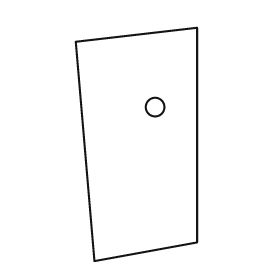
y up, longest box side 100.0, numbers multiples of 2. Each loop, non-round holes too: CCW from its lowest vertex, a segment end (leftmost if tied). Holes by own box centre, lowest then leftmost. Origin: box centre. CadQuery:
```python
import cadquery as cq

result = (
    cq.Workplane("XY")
    .moveTo(-18.0, -50.0)
    .lineTo(26.0, -42.0)
    .lineTo(26.0, 50.0)
    .lineTo(-26.0, 44.0)
    .close()
    .moveTo(8.0, 16.0)
    .circle(4.0)
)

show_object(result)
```